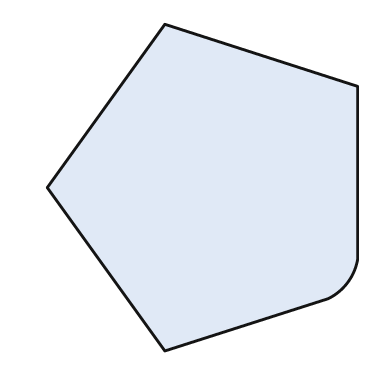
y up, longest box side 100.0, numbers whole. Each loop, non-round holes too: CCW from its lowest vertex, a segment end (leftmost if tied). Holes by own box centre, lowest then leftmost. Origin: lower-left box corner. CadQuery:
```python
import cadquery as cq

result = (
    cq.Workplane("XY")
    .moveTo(36.0, 0.0)
    .lineTo(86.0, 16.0)
    .threePointArc((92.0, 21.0), (95.0, 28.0))
    .lineTo(95.0, 81.0)
    .lineTo(36.0, 100.0)
    .lineTo(0.0, 50.0)
    .close()
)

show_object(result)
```